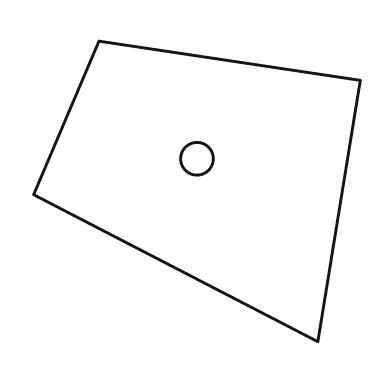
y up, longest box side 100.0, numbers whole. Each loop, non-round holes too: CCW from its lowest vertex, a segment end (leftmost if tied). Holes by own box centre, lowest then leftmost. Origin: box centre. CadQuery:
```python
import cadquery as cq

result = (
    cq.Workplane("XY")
    .moveTo(37.0, -46.0)
    .lineTo(50.0, 34.0)
    .lineTo(-30.0, 46.0)
    .lineTo(-50.0, -1.0)
    .close()
    .moveTo(0.0, 10.0)
    .circle(5.0)
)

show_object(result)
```